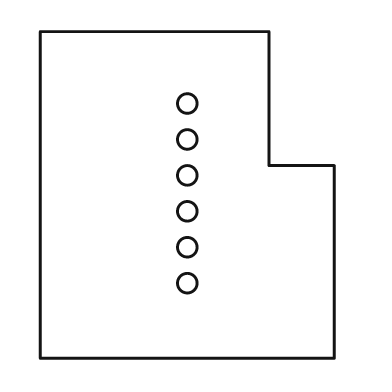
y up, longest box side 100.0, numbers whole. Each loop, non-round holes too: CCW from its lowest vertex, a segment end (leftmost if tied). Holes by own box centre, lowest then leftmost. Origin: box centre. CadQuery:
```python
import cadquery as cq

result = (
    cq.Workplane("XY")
    .moveTo(-45.0, -50.0)
    .lineTo(45.0, -50.0)
    .lineTo(45.0, 9.0)
    .lineTo(25.0, 9.0)
    .lineTo(25.0, 50.0)
    .lineTo(-45.0, 50.0)
    .close()
    .moveTo(0.0, -27.0)
    .circle(3.0)
    .moveTo(0.0, -16.0)
    .circle(3.0)
    .moveTo(0.0, -5.0)
    .circle(3.0)
    .moveTo(0.0, 6.0)
    .circle(3.0)
    .moveTo(0.0, 17.0)
    .circle(3.0)
    .moveTo(0.0, 28.0)
    .circle(3.0)
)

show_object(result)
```